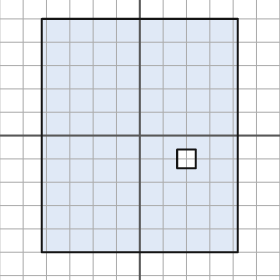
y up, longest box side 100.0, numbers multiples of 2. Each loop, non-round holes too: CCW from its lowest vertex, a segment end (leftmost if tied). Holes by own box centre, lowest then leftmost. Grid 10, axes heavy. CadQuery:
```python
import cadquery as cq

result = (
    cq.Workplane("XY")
    .moveTo(-42.0, -50.0)
    .lineTo(42.0, -50.0)
    .lineTo(42.0, 50.0)
    .lineTo(-42.0, 50.0)
    .close()
    .moveTo(16.0, -14.0)
    .lineTo(24.0, -14.0)
    .lineTo(24.0, -6.0)
    .lineTo(16.0, -6.0)
    .close()
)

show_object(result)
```